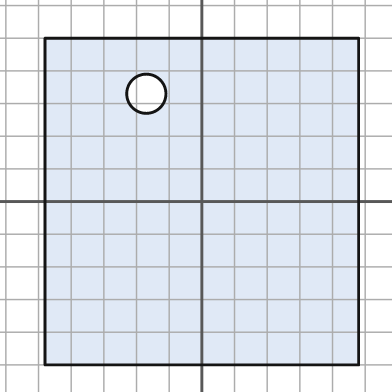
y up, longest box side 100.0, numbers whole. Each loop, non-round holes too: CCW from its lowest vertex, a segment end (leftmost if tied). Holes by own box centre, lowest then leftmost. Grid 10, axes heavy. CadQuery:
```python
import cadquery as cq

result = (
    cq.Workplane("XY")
    .moveTo(-48.0, -50.0)
    .lineTo(48.0, -50.0)
    .lineTo(48.0, 50.0)
    .lineTo(-48.0, 50.0)
    .close()
    .moveTo(-17.0, 33.0)
    .circle(6.0)
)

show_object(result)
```